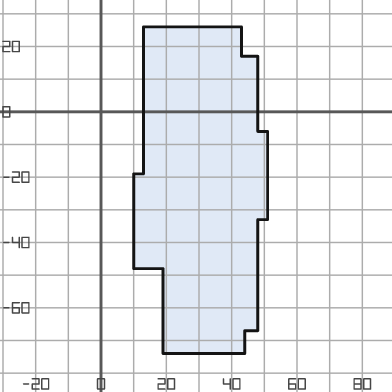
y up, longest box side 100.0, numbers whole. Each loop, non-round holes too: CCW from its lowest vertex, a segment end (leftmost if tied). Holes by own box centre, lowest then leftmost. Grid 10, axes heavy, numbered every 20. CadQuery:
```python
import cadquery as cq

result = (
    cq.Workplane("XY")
    .moveTo(19.0, -74.0)
    .lineTo(44.0, -74.0)
    .lineTo(44.0, -67.0)
    .lineTo(48.0, -67.0)
    .lineTo(48.0, -33.0)
    .lineTo(51.0, -33.0)
    .lineTo(51.0, -6.0)
    .lineTo(48.0, -6.0)
    .lineTo(48.0, 17.0)
    .lineTo(43.0, 17.0)
    .lineTo(43.0, 26.0)
    .lineTo(13.0, 26.0)
    .lineTo(13.0, -19.0)
    .lineTo(10.0, -19.0)
    .lineTo(10.0, -48.0)
    .lineTo(19.0, -48.0)
    .close()
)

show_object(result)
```